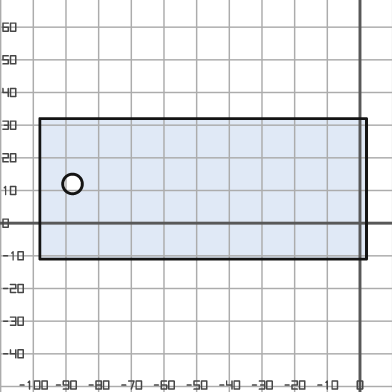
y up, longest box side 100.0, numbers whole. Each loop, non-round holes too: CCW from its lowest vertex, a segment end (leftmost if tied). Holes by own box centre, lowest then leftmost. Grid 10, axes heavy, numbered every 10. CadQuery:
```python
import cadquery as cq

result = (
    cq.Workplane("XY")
    .moveTo(-98.0, -11.0)
    .lineTo(2.0, -11.0)
    .lineTo(2.0, 32.0)
    .lineTo(-98.0, 32.0)
    .close()
    .moveTo(-88.0, 12.0)
    .circle(3.0)
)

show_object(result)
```